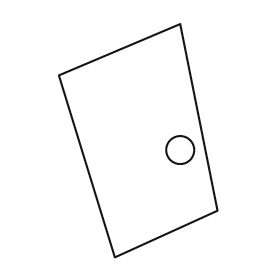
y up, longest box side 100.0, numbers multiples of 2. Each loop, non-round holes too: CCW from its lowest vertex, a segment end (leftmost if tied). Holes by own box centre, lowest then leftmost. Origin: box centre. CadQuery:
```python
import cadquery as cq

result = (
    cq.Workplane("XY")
    .moveTo(-10.0, -50.0)
    .lineTo(34.0, -30.0)
    .lineTo(18.0, 50.0)
    .lineTo(-34.0, 28.0)
    .close()
    .moveTo(18.0, -4.0)
    .circle(6.0)
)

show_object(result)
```